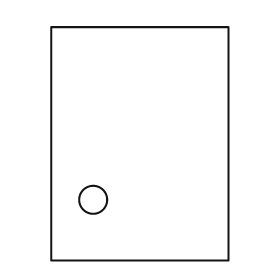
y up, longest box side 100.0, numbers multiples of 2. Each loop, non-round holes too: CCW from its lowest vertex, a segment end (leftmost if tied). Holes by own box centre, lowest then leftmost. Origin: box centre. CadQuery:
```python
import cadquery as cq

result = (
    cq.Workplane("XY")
    .moveTo(-38.0, -50.0)
    .lineTo(38.0, -50.0)
    .lineTo(38.0, 50.0)
    .lineTo(-38.0, 50.0)
    .close()
    .moveTo(-20.0, -24.0)
    .circle(6.0)
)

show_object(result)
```